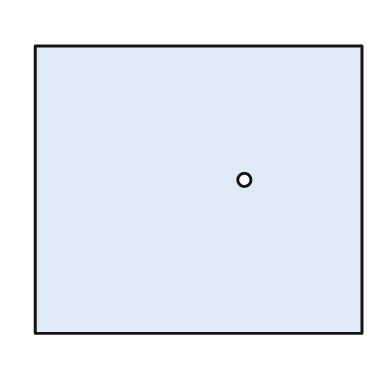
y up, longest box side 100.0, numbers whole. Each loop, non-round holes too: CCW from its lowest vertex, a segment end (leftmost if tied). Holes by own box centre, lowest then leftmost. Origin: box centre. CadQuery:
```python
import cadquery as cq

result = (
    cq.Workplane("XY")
    .moveTo(-50.0, -44.0)
    .lineTo(50.0, -44.0)
    .lineTo(50.0, 44.0)
    .lineTo(-50.0, 44.0)
    .close()
    .moveTo(14.0, 3.0)
    .circle(2.0)
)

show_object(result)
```